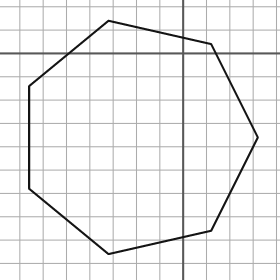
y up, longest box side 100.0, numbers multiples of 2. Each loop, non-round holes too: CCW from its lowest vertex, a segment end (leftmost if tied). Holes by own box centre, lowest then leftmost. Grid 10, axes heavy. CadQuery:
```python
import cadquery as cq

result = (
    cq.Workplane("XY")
    .moveTo(-32.0, -86.0)
    .lineTo(12.0, -76.0)
    .lineTo(32.0, -36.0)
    .lineTo(12.0, 4.0)
    .lineTo(-32.0, 14.0)
    .lineTo(-66.0, -14.0)
    .lineTo(-66.0, -58.0)
    .close()
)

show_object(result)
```